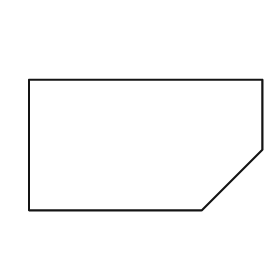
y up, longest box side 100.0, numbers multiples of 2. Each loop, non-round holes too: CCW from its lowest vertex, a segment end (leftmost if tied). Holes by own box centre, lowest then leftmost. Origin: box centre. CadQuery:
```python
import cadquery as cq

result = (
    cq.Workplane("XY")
    .moveTo(-50.0, -28.0)
    .lineTo(24.0, -28.0)
    .lineTo(50.0, -2.0)
    .lineTo(50.0, 28.0)
    .lineTo(-50.0, 28.0)
    .close()
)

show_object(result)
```